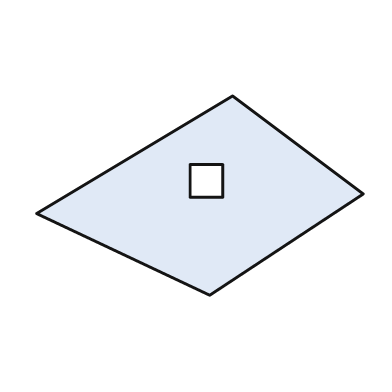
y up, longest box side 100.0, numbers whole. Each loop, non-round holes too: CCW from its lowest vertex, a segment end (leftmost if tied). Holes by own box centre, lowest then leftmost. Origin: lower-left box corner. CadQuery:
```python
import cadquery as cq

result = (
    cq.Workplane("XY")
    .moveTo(53.0, 0.0)
    .lineTo(100.0, 31.0)
    .lineTo(60.0, 61.0)
    .lineTo(0.0, 25.0)
    .close()
    .moveTo(47.0, 30.0)
    .lineTo(57.0, 30.0)
    .lineTo(57.0, 40.0)
    .lineTo(47.0, 40.0)
    .close()
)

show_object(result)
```